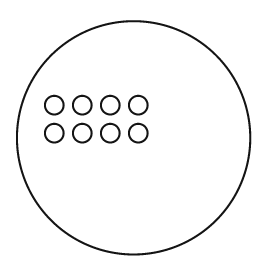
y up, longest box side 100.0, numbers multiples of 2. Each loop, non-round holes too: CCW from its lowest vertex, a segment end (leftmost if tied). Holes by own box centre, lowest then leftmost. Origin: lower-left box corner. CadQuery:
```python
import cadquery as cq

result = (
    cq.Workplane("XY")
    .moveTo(50.0, 50.0)
    .circle(50.0)
    .moveTo(16.0, 52.0)
    .circle(4.0)
    .moveTo(28.0, 52.0)
    .circle(4.0)
    .moveTo(40.0, 52.0)
    .circle(4.0)
    .moveTo(52.0, 52.0)
    .circle(4.0)
    .moveTo(16.0, 64.0)
    .circle(4.0)
    .moveTo(28.0, 64.0)
    .circle(4.0)
    .moveTo(40.0, 64.0)
    .circle(4.0)
    .moveTo(52.0, 64.0)
    .circle(4.0)
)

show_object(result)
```